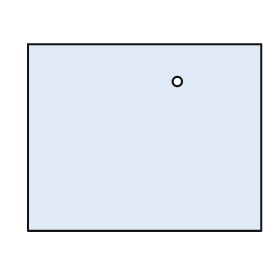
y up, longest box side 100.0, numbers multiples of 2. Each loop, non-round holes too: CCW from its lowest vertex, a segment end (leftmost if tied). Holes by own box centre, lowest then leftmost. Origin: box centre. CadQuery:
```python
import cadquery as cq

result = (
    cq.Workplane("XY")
    .moveTo(-50.0, -40.0)
    .lineTo(50.0, -40.0)
    .lineTo(50.0, 40.0)
    .lineTo(-50.0, 40.0)
    .close()
    .moveTo(14.0, 24.0)
    .circle(2.0)
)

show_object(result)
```